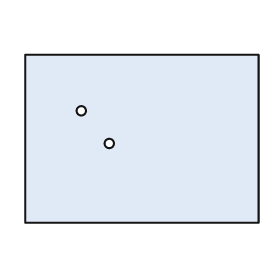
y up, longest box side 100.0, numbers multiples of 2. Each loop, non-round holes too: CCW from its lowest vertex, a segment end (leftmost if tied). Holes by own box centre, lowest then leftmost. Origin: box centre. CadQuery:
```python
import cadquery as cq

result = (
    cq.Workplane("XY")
    .moveTo(-50.0, -36.0)
    .lineTo(50.0, -36.0)
    .lineTo(50.0, 36.0)
    .lineTo(-50.0, 36.0)
    .close()
    .moveTo(-14.0, -2.0)
    .circle(2.0)
    .moveTo(-26.0, 12.0)
    .circle(2.0)
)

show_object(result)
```